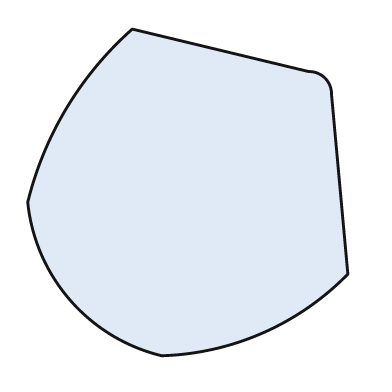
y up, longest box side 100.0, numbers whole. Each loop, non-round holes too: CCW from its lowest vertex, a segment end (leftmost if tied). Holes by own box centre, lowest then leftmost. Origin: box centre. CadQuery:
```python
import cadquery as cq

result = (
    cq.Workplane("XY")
    .moveTo(-8.0, -50.0)
    .threePointArc((23.0, -43.0), (49.0, -25.0))
    .lineTo(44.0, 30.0)
    .threePointArc((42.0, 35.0), (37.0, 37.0))
    .lineTo(-17.0, 50.0)
    .threePointArc((-37.0, 26.0), (-49.0, -3.0))
    .threePointArc((-36.0, -33.0), (-8.0, -50.0))
    .close()
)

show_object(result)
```